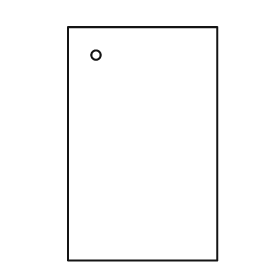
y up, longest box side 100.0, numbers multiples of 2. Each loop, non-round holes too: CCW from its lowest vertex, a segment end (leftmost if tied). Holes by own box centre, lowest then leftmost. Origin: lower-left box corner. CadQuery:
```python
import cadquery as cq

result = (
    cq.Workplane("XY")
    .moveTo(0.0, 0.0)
    .lineTo(64.0, 0.0)
    .lineTo(64.0, 100.0)
    .lineTo(0.0, 100.0)
    .close()
    .moveTo(12.0, 88.0)
    .circle(2.0)
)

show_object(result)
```